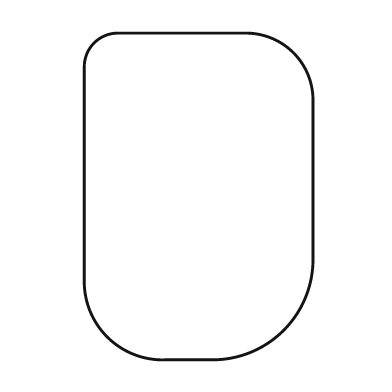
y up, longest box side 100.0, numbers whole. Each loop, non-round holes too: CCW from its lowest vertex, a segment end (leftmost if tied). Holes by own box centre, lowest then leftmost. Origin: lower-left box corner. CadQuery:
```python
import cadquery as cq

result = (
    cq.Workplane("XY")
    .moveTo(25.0, 0.0)
    .lineTo(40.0, 0.0)
    .threePointArc((61.0, 9.0), (70.0, 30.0))
    .lineTo(70.0, 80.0)
    .threePointArc((64.0, 94.0), (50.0, 100.0))
    .lineTo(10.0, 100.0)
    .threePointArc((3.0, 97.0), (0.0, 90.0))
    .lineTo(0.0, 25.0)
    .threePointArc((7.0, 7.0), (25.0, 0.0))
    .close()
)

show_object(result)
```